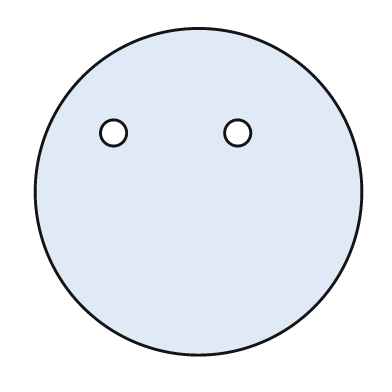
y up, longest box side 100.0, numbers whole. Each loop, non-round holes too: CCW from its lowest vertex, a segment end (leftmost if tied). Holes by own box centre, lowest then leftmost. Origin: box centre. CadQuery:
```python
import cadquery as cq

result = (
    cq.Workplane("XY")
    .moveTo(0.0, 0.0)
    .circle(50.0)
    .moveTo(-26.0, 18.0)
    .circle(4.0)
    .moveTo(12.0, 18.0)
    .circle(4.0)
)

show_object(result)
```